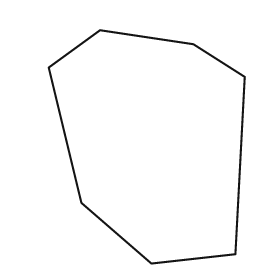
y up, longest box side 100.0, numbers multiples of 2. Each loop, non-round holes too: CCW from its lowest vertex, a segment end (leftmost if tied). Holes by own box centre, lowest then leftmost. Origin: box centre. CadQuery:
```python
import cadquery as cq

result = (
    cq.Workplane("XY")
    .moveTo(2.0, -50.0)
    .lineTo(38.0, -46.0)
    .lineTo(42.0, 30.0)
    .lineTo(20.0, 44.0)
    .lineTo(-20.0, 50.0)
    .lineTo(-42.0, 34.0)
    .lineTo(-28.0, -24.0)
    .close()
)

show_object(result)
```